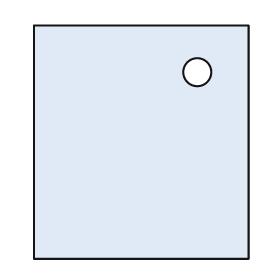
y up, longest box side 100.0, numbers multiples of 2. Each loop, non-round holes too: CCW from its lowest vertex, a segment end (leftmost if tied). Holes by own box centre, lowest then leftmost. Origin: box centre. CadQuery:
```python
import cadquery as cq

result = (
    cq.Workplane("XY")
    .moveTo(-46.0, -50.0)
    .lineTo(46.0, -50.0)
    .lineTo(46.0, 50.0)
    .lineTo(-46.0, 50.0)
    .close()
    .moveTo(24.0, 30.0)
    .circle(6.0)
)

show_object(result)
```